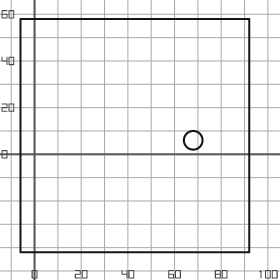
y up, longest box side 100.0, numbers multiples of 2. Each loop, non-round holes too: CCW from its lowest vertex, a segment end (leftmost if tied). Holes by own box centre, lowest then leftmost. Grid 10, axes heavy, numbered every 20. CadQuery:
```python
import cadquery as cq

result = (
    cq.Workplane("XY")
    .moveTo(-6.0, -42.0)
    .lineTo(92.0, -42.0)
    .lineTo(92.0, 58.0)
    .lineTo(-6.0, 58.0)
    .close()
    .moveTo(68.0, 6.0)
    .circle(4.0)
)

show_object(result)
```